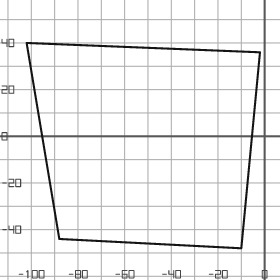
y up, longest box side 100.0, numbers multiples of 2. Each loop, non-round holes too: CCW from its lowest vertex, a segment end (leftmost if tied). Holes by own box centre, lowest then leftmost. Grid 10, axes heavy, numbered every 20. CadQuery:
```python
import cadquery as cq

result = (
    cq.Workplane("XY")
    .moveTo(-10.0, -48.0)
    .lineTo(-2.0, 36.0)
    .lineTo(-102.0, 40.0)
    .lineTo(-88.0, -44.0)
    .close()
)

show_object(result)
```